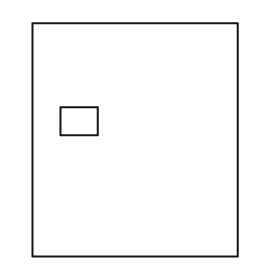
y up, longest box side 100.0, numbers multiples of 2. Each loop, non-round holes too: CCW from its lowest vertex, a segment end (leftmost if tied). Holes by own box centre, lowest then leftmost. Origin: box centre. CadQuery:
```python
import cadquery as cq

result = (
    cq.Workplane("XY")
    .moveTo(-44.0, -50.0)
    .lineTo(44.0, -50.0)
    .lineTo(44.0, 50.0)
    .lineTo(-44.0, 50.0)
    .close()
    .moveTo(-32.0, 2.0)
    .lineTo(-16.0, 2.0)
    .lineTo(-16.0, 14.0)
    .lineTo(-32.0, 14.0)
    .close()
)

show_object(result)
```